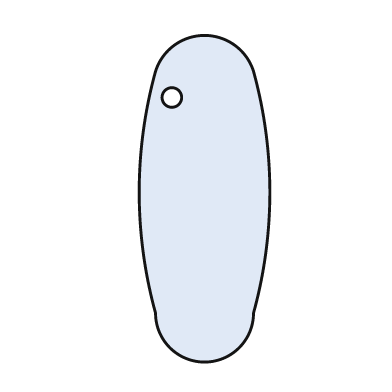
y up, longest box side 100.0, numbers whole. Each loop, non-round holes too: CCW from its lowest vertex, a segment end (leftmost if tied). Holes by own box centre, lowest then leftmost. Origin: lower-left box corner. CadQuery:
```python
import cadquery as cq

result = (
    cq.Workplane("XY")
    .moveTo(5.0, 15.0)
    .threePointArc((20.0, 0.0), (35.0, 15.0))
    .threePointArc((40.0, 52.0), (35.0, 89.0))
    .threePointArc((20.0, 100.0), (5.0, 89.0))
    .threePointArc((0.0, 52.0), (5.0, 15.0))
    .close()
    .moveTo(10.0, 81.0)
    .circle(3.0)
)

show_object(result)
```